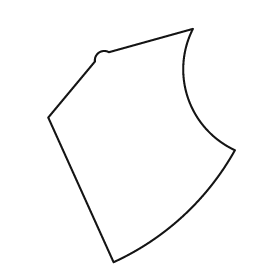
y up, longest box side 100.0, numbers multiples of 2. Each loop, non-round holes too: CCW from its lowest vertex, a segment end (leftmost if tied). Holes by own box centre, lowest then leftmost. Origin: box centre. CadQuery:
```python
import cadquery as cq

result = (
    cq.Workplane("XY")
    .moveTo(-12.0, -50.0)
    .threePointArc((18.0, -30.0), (40.0, -2.0))
    .threePointArc((20.0, 20.0), (22.0, 50.0))
    .lineTo(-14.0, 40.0)
    .threePointArc((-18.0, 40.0), (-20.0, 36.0))
    .lineTo(-40.0, 12.0)
    .close()
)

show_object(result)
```